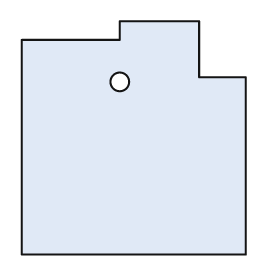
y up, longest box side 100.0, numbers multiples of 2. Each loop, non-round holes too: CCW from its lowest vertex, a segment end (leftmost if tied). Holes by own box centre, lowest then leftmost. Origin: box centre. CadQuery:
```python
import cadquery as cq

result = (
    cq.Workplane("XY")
    .moveTo(-48.0, -50.0)
    .lineTo(48.0, -50.0)
    .lineTo(48.0, 26.0)
    .lineTo(28.0, 26.0)
    .lineTo(28.0, 50.0)
    .lineTo(-6.0, 50.0)
    .lineTo(-6.0, 42.0)
    .lineTo(-48.0, 42.0)
    .close()
    .moveTo(-6.0, 24.0)
    .circle(4.0)
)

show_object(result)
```